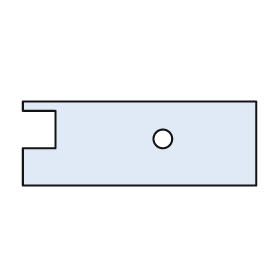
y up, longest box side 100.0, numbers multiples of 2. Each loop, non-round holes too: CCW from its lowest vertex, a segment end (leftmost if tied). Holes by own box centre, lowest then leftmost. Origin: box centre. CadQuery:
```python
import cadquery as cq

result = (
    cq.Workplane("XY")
    .moveTo(-50.0, -18.0)
    .lineTo(50.0, -18.0)
    .lineTo(50.0, 18.0)
    .lineTo(-50.0, 18.0)
    .lineTo(-50.0, 14.0)
    .lineTo(-36.0, 14.0)
    .lineTo(-36.0, -2.0)
    .lineTo(-50.0, -2.0)
    .close()
    .moveTo(10.0, 2.0)
    .circle(4.0)
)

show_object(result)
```